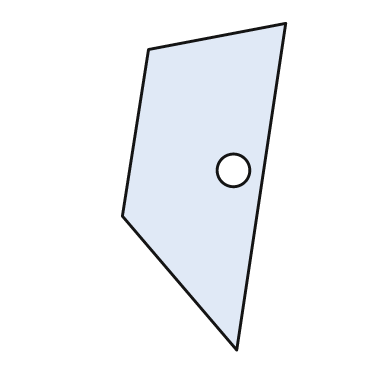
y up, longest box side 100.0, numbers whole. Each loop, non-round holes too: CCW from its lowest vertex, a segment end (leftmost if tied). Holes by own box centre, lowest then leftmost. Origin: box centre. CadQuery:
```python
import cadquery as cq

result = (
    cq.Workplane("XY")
    .moveTo(10.0, -50.0)
    .lineTo(25.0, 50.0)
    .lineTo(-17.0, 42.0)
    .lineTo(-25.0, -9.0)
    .close()
    .moveTo(9.0, 5.0)
    .circle(5.0)
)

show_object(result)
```